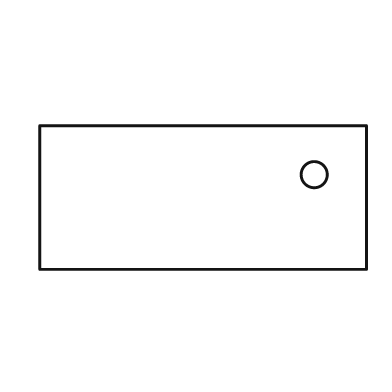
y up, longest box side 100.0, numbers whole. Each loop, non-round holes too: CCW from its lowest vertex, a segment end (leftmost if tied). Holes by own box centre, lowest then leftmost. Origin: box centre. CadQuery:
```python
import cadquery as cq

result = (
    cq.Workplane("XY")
    .moveTo(-50.0, -22.0)
    .lineTo(50.0, -22.0)
    .lineTo(50.0, 22.0)
    .lineTo(-50.0, 22.0)
    .close()
    .moveTo(34.0, 7.0)
    .circle(4.0)
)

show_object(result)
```